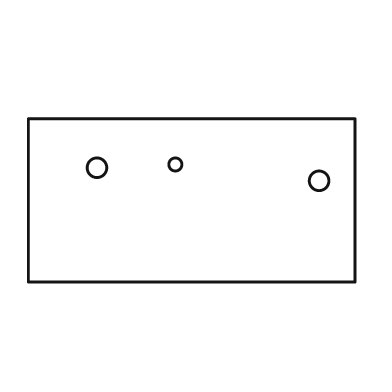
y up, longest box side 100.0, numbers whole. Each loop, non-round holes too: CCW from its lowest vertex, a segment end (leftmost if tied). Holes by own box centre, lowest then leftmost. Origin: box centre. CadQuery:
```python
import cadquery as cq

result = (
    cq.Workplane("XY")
    .moveTo(-50.0, -25.0)
    .lineTo(50.0, -25.0)
    .lineTo(50.0, 25.0)
    .lineTo(-50.0, 25.0)
    .close()
    .moveTo(39.0, 6.0)
    .circle(3.0)
    .moveTo(-29.0, 10.0)
    .circle(3.0)
    .moveTo(-5.0, 11.0)
    .circle(2.0)
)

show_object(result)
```